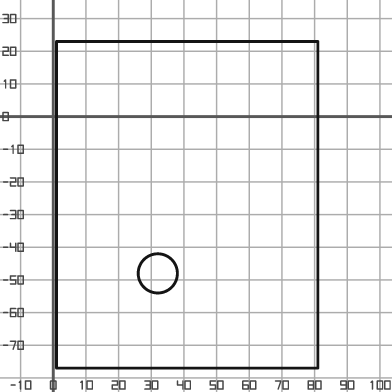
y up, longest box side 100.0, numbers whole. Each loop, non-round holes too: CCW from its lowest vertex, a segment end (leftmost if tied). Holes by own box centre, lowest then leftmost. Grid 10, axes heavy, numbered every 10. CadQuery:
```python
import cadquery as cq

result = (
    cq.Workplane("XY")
    .moveTo(1.0, -77.0)
    .lineTo(81.0, -77.0)
    .lineTo(81.0, 23.0)
    .lineTo(1.0, 23.0)
    .close()
    .moveTo(32.0, -48.0)
    .circle(6.0)
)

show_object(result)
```